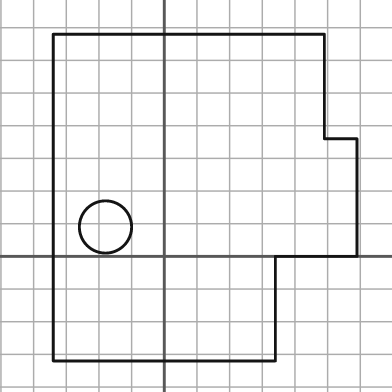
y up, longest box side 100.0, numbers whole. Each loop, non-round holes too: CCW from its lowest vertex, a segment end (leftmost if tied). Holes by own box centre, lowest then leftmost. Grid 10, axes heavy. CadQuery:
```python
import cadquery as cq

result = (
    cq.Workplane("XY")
    .moveTo(-34.0, -32.0)
    .lineTo(34.0, -32.0)
    .lineTo(34.0, 0.0)
    .lineTo(59.0, 0.0)
    .lineTo(59.0, 36.0)
    .lineTo(49.0, 36.0)
    .lineTo(49.0, 68.0)
    .lineTo(-34.0, 68.0)
    .close()
    .moveTo(-18.0, 9.0)
    .circle(8.0)
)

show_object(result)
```